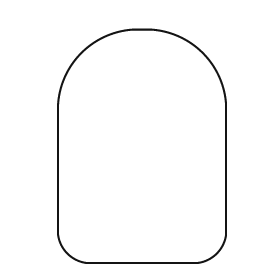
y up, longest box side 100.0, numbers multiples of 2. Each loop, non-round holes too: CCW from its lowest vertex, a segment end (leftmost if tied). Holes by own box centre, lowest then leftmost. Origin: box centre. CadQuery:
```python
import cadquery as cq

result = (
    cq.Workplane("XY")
    .moveTo(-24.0, -50.0)
    .lineTo(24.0, -50.0)
    .threePointArc((32.0, -46.0), (36.0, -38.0))
    .lineTo(36.0, 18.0)
    .threePointArc((26.0, 40.0), (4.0, 50.0))
    .lineTo(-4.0, 50.0)
    .threePointArc((-26.0, 40.0), (-36.0, 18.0))
    .lineTo(-36.0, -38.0)
    .threePointArc((-32.0, -46.0), (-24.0, -50.0))
    .close()
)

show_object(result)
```